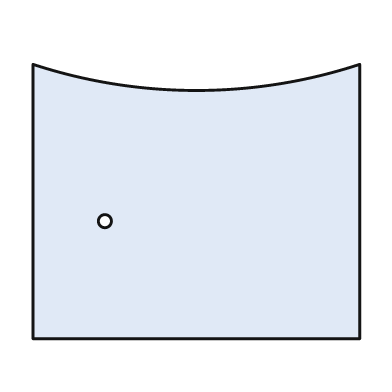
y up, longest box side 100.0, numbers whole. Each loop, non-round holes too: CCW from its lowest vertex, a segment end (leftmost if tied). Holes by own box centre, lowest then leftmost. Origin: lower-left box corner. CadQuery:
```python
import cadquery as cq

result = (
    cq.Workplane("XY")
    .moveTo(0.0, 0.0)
    .lineTo(100.0, 0.0)
    .lineTo(100.0, 84.0)
    .threePointArc((50.0, 76.0), (0.0, 84.0))
    .close()
    .moveTo(22.0, 36.0)
    .circle(2.0)
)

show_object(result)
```